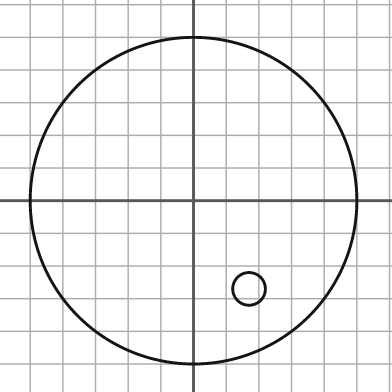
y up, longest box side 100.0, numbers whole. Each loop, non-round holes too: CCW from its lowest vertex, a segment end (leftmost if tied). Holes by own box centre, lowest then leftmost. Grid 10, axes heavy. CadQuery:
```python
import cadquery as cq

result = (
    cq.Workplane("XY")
    .moveTo(0.0, 0.0)
    .circle(50.0)
    .moveTo(17.0, -27.0)
    .circle(5.0)
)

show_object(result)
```